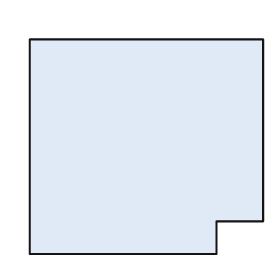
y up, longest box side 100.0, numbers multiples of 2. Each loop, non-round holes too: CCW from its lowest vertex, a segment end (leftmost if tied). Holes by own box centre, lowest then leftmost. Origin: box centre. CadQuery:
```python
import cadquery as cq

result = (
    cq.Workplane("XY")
    .moveTo(-50.0, -46.0)
    .lineTo(30.0, -46.0)
    .lineTo(30.0, -32.0)
    .lineTo(50.0, -32.0)
    .lineTo(50.0, 46.0)
    .lineTo(-50.0, 46.0)
    .close()
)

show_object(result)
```